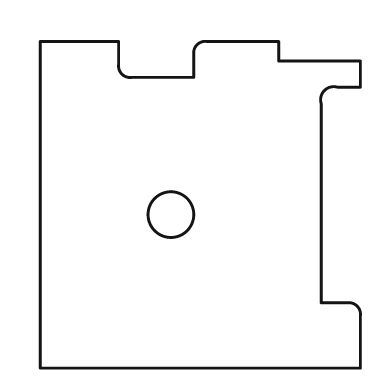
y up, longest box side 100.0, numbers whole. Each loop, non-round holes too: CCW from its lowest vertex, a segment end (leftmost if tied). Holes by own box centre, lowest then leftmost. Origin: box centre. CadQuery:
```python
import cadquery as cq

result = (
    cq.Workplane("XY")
    .moveTo(-49.0, -50.0)
    .lineTo(49.0, -50.0)
    .lineTo(49.0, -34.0)
    .threePointArc((48.0, -31.0), (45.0, -30.0))
    .lineTo(37.0, -30.0)
    .lineTo(37.0, 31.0)
    .threePointArc((38.0, 35.0), (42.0, 36.0))
    .lineTo(49.0, 36.0)
    .lineTo(49.0, 44.0)
    .lineTo(24.0, 44.0)
    .lineTo(24.0, 50.0)
    .lineTo(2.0, 50.0)
    .threePointArc((-1.0, 49.0), (-2.0, 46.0))
    .lineTo(-2.0, 39.0)
    .lineTo(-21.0, 39.0)
    .threePointArc((-24.0, 40.0), (-25.0, 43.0))
    .lineTo(-25.0, 50.0)
    .lineTo(-49.0, 50.0)
    .close()
    .moveTo(-9.0, -3.0)
    .circle(7.0)
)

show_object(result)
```